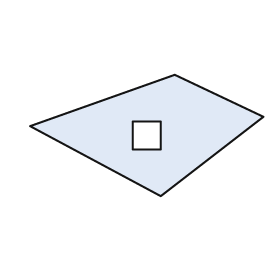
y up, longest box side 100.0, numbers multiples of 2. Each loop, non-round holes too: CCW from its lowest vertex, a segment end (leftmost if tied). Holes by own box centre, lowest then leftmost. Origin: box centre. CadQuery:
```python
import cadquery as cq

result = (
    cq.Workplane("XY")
    .moveTo(6.0, -26.0)
    .lineTo(50.0, 8.0)
    .lineTo(12.0, 26.0)
    .lineTo(-50.0, 4.0)
    .close()
    .moveTo(-6.0, -6.0)
    .lineTo(6.0, -6.0)
    .lineTo(6.0, 6.0)
    .lineTo(-6.0, 6.0)
    .close()
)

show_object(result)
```